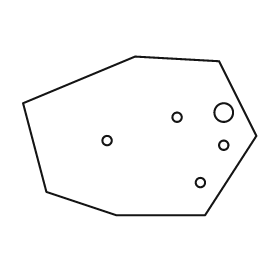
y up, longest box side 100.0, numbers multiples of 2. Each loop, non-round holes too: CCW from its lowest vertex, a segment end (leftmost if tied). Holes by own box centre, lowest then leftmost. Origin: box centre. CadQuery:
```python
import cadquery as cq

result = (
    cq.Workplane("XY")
    .moveTo(-10.0, -34.0)
    .lineTo(28.0, -34.0)
    .lineTo(50.0, 0.0)
    .lineTo(34.0, 32.0)
    .lineTo(-2.0, 34.0)
    .lineTo(-50.0, 14.0)
    .lineTo(-40.0, -24.0)
    .close()
    .moveTo(26.0, -20.0)
    .circle(2.0)
    .moveTo(36.0, -4.0)
    .circle(2.0)
    .moveTo(-14.0, -2.0)
    .circle(2.0)
    .moveTo(16.0, 8.0)
    .circle(2.0)
    .moveTo(36.0, 10.0)
    .circle(4.0)
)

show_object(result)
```